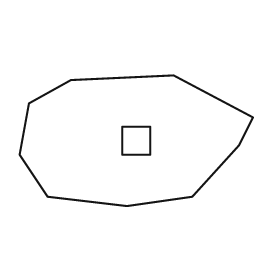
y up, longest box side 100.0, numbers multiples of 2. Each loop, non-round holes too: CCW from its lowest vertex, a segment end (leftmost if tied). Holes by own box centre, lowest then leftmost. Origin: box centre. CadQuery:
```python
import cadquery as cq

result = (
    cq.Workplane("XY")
    .moveTo(-4.0, -28.0)
    .lineTo(24.0, -24.0)
    .lineTo(44.0, -2.0)
    .lineTo(50.0, 10.0)
    .lineTo(16.0, 28.0)
    .lineTo(-28.0, 26.0)
    .lineTo(-46.0, 16.0)
    .lineTo(-50.0, -6.0)
    .lineTo(-38.0, -24.0)
    .close()
    .moveTo(-6.0, -6.0)
    .lineTo(6.0, -6.0)
    .lineTo(6.0, 6.0)
    .lineTo(-6.0, 6.0)
    .close()
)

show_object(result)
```